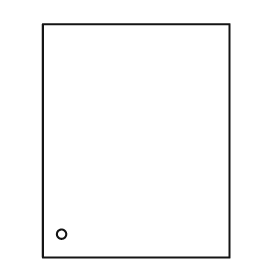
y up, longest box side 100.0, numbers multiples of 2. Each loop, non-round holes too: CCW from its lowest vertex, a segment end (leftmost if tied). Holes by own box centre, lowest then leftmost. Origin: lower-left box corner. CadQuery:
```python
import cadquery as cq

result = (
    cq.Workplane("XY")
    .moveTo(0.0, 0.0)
    .lineTo(80.0, 0.0)
    .lineTo(80.0, 100.0)
    .lineTo(0.0, 100.0)
    .close()
    .moveTo(8.0, 10.0)
    .circle(2.0)
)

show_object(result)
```